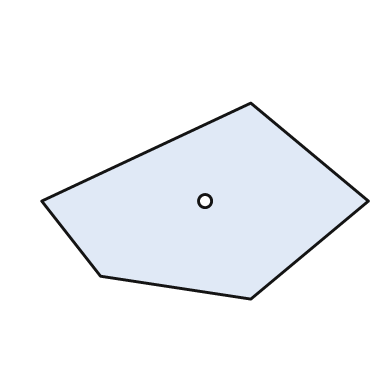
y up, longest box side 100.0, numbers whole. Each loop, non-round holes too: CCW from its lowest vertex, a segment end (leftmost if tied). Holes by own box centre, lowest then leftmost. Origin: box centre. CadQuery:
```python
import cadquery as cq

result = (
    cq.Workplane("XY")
    .moveTo(14.0, -30.0)
    .lineTo(50.0, 0.0)
    .lineTo(14.0, 30.0)
    .lineTo(-50.0, 0.0)
    .lineTo(-32.0, -23.0)
    .close()
    .moveTo(0.0, 0.0)
    .circle(2.0)
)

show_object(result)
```